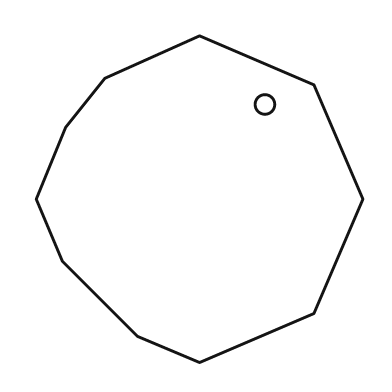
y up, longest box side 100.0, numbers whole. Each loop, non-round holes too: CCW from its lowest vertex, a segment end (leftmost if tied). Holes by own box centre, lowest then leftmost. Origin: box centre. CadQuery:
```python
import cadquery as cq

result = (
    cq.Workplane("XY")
    .moveTo(0.0, -50.0)
    .lineTo(35.0, -35.0)
    .lineTo(50.0, 0.0)
    .lineTo(35.0, 35.0)
    .lineTo(0.0, 50.0)
    .lineTo(-29.0, 37.0)
    .lineTo(-41.0, 22.0)
    .lineTo(-50.0, 0.0)
    .lineTo(-42.0, -19.0)
    .lineTo(-19.0, -42.0)
    .close()
    .moveTo(20.0, 29.0)
    .circle(3.0)
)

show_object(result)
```